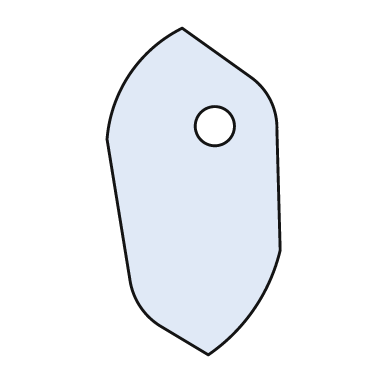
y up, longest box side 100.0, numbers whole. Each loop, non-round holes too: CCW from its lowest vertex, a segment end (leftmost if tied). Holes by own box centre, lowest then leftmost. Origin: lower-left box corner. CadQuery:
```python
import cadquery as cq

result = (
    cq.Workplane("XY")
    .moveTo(31.0, 0.0)
    .threePointArc((45.0, 14.0), (53.0, 32.0))
    .lineTo(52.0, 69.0)
    .threePointArc((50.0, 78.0), (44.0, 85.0))
    .lineTo(23.0, 100.0)
    .threePointArc((7.0, 86.0), (0.0, 66.0))
    .lineTo(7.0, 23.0)
    .threePointArc((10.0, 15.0), (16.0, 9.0))
    .close()
    .moveTo(33.0, 70.0)
    .circle(6.0)
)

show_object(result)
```